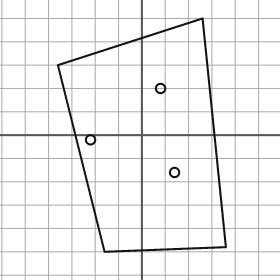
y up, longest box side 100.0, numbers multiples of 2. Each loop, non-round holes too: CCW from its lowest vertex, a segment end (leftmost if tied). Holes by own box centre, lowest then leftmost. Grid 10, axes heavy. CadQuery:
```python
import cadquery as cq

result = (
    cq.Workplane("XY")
    .moveTo(-16.0, -50.0)
    .lineTo(36.0, -48.0)
    .lineTo(26.0, 50.0)
    .lineTo(-36.0, 30.0)
    .close()
    .moveTo(14.0, -16.0)
    .circle(2.0)
    .moveTo(-22.0, -2.0)
    .circle(2.0)
    .moveTo(8.0, 20.0)
    .circle(2.0)
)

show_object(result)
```